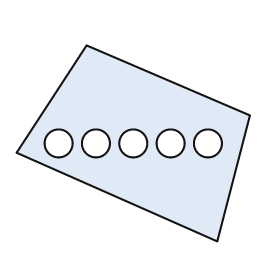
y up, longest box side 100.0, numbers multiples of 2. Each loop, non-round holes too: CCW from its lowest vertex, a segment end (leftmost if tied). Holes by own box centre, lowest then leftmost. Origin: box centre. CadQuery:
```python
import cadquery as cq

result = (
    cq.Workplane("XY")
    .moveTo(36.0, -42.0)
    .lineTo(50.0, 12.0)
    .lineTo(-20.0, 42.0)
    .lineTo(-50.0, -4.0)
    .close()
    .moveTo(-32.0, 0.0)
    .circle(6.0)
    .moveTo(-16.0, 0.0)
    .circle(6.0)
    .moveTo(0.0, 0.0)
    .circle(6.0)
    .moveTo(16.0, 0.0)
    .circle(6.0)
    .moveTo(32.0, 0.0)
    .circle(6.0)
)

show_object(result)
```